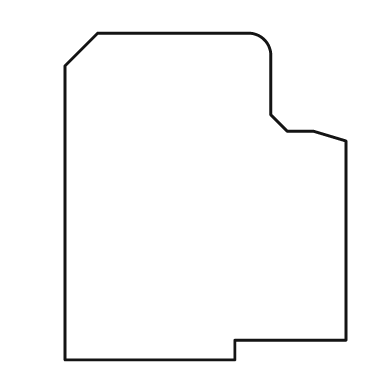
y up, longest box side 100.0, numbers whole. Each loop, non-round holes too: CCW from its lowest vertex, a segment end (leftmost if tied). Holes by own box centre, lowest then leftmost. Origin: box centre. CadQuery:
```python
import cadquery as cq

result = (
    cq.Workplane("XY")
    .moveTo(-43.0, -50.0)
    .lineTo(9.0, -50.0)
    .lineTo(9.0, -44.0)
    .lineTo(43.0, -44.0)
    .lineTo(43.0, 17.0)
    .lineTo(33.0, 20.0)
    .lineTo(25.0, 20.0)
    .lineTo(20.0, 25.0)
    .lineTo(20.0, 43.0)
    .threePointArc((18.0, 48.0), (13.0, 50.0))
    .lineTo(-33.0, 50.0)
    .lineTo(-43.0, 40.0)
    .close()
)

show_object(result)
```